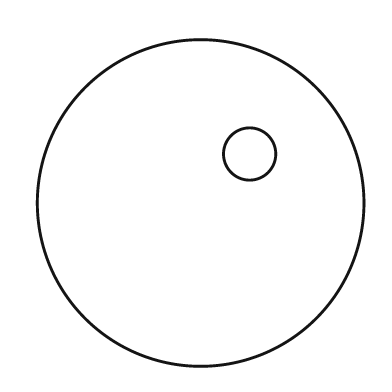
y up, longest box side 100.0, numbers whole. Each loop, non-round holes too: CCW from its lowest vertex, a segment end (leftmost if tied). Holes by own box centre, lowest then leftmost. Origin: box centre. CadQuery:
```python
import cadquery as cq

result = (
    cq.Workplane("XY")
    .moveTo(0.0, 0.0)
    .circle(50.0)
    .moveTo(15.0, 15.0)
    .circle(8.0)
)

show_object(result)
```